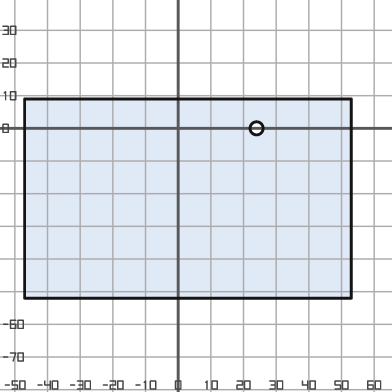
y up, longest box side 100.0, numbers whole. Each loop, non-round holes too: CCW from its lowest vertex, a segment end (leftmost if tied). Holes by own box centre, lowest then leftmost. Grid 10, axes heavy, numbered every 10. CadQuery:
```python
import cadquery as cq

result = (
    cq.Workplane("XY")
    .moveTo(-47.0, -52.0)
    .lineTo(53.0, -52.0)
    .lineTo(53.0, 9.0)
    .lineTo(-47.0, 9.0)
    .close()
    .moveTo(24.0, 0.0)
    .circle(2.0)
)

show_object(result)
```